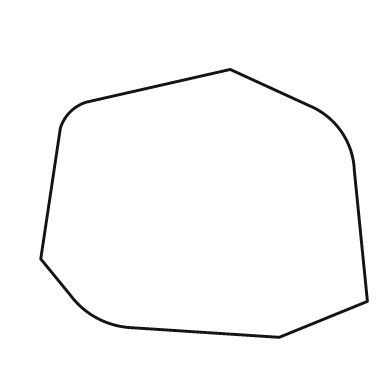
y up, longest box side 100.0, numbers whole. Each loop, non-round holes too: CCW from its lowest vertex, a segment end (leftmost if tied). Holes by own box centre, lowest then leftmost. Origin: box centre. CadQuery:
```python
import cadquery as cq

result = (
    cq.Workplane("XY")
    .moveTo(23.0, -41.0)
    .lineTo(50.0, -30.0)
    .lineTo(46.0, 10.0)
    .threePointArc((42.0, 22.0), (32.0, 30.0))
    .lineTo(8.0, 41.0)
    .lineTo(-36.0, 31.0)
    .threePointArc((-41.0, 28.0), (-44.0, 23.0))
    .lineTo(-50.0, -17.0)
    .lineTo(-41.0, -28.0)
    .threePointArc((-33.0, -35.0), (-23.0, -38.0))
    .close()
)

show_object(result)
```